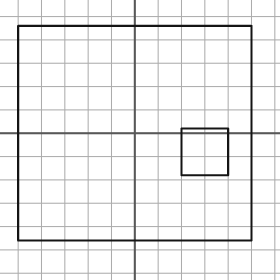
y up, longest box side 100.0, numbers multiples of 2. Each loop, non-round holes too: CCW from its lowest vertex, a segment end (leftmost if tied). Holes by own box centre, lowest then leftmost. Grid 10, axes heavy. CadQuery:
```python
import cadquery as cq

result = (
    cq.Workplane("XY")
    .moveTo(-50.0, -46.0)
    .lineTo(50.0, -46.0)
    .lineTo(50.0, 46.0)
    .lineTo(-50.0, 46.0)
    .close()
    .moveTo(20.0, -18.0)
    .lineTo(40.0, -18.0)
    .lineTo(40.0, 2.0)
    .lineTo(20.0, 2.0)
    .close()
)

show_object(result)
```